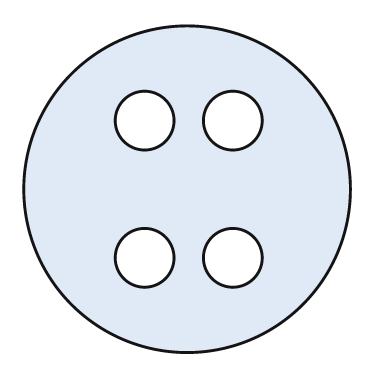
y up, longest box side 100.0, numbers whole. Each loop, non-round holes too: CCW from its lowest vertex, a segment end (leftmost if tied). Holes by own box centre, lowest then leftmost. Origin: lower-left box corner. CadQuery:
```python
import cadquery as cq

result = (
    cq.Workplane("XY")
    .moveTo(50.0, 50.0)
    .circle(50.0)
    .moveTo(37.0, 29.0)
    .circle(9.0)
    .moveTo(64.0, 29.0)
    .circle(9.0)
    .moveTo(37.0, 71.0)
    .circle(9.0)
    .moveTo(64.0, 71.0)
    .circle(9.0)
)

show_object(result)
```